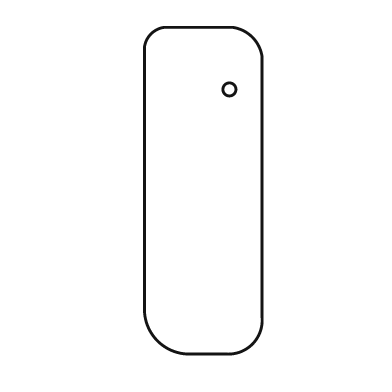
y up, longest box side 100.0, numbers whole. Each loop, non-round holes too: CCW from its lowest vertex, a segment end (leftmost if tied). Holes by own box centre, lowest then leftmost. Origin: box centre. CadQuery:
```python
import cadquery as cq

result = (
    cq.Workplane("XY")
    .moveTo(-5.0, -50.0)
    .lineTo(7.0, -50.0)
    .threePointArc((15.0, -47.0), (18.0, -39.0))
    .lineTo(18.0, 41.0)
    .threePointArc((15.0, 47.0), (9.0, 50.0))
    .lineTo(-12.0, 50.0)
    .threePointArc((-16.0, 48.0), (-18.0, 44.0))
    .lineTo(-18.0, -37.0)
    .threePointArc((-14.0, -46.0), (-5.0, -50.0))
    .close()
    .moveTo(8.0, 31.0)
    .circle(2.0)
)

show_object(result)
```